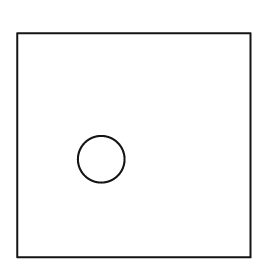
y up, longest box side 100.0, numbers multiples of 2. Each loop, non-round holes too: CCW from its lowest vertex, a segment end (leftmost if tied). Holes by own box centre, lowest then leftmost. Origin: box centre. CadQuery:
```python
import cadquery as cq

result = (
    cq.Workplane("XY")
    .moveTo(-50.0, -48.0)
    .lineTo(50.0, -48.0)
    .lineTo(50.0, 48.0)
    .lineTo(-50.0, 48.0)
    .close()
    .moveTo(-14.0, -6.0)
    .circle(10.0)
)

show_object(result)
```